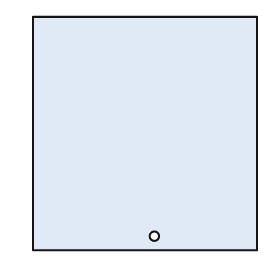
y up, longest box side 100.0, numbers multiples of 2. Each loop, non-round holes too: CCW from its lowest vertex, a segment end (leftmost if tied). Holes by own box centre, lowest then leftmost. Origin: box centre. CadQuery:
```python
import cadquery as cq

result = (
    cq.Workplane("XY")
    .moveTo(-48.0, -50.0)
    .lineTo(48.0, -50.0)
    .lineTo(48.0, 50.0)
    .lineTo(-48.0, 50.0)
    .close()
    .moveTo(4.0, -44.0)
    .circle(2.0)
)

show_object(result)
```